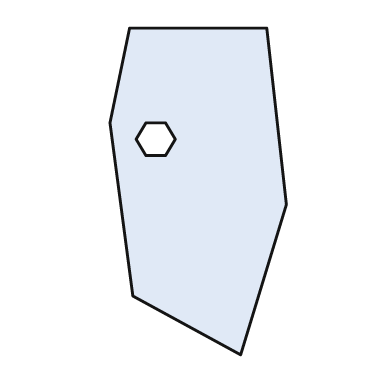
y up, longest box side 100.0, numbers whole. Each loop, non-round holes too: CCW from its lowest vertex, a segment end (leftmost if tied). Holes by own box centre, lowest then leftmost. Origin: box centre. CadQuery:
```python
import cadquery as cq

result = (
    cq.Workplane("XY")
    .moveTo(13.0, -50.0)
    .lineTo(27.0, -4.0)
    .lineTo(21.0, 50.0)
    .lineTo(-21.0, 50.0)
    .lineTo(-27.0, 21.0)
    .lineTo(-20.0, -32.0)
    .close()
    .moveTo(-16.0, 11.0)
    .lineTo(-10.0, 11.0)
    .lineTo(-7.0, 16.0)
    .lineTo(-10.0, 21.0)
    .lineTo(-16.0, 21.0)
    .lineTo(-19.0, 16.0)
    .close()
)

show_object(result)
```